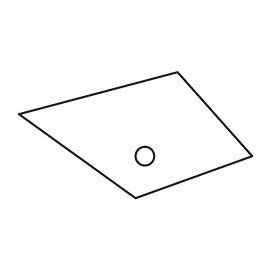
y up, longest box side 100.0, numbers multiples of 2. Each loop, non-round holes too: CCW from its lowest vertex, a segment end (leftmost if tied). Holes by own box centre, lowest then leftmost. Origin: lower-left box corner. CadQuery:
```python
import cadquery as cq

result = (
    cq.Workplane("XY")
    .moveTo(50.0, 0.0)
    .lineTo(100.0, 18.0)
    .lineTo(68.0, 54.0)
    .lineTo(0.0, 36.0)
    .close()
    .moveTo(54.0, 18.0)
    .circle(4.0)
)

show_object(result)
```